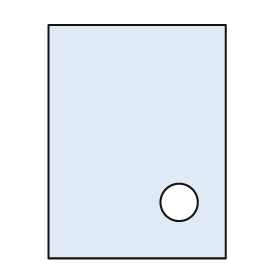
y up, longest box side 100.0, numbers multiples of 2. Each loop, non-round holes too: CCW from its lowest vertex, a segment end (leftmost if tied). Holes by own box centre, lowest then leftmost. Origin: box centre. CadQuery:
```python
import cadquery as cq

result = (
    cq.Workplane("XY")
    .moveTo(-38.0, -50.0)
    .lineTo(38.0, -50.0)
    .lineTo(38.0, 50.0)
    .lineTo(-38.0, 50.0)
    .close()
    .moveTo(18.0, -26.0)
    .circle(8.0)
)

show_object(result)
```